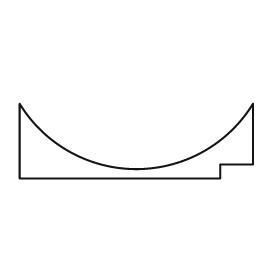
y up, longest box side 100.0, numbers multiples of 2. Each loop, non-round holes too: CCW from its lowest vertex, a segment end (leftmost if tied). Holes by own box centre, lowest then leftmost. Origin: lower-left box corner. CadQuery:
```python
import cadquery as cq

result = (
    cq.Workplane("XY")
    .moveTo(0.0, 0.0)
    .lineTo(86.0, 0.0)
    .lineTo(86.0, 6.0)
    .lineTo(100.0, 6.0)
    .lineTo(100.0, 32.0)
    .threePointArc((50.0, 4.0), (0.0, 32.0))
    .close()
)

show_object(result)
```